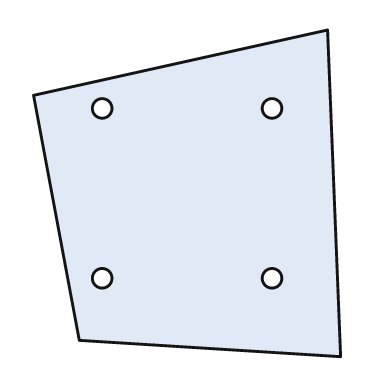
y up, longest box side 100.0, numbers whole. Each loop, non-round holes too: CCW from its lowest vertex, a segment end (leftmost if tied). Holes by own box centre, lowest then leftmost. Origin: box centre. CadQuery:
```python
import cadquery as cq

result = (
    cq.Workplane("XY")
    .moveTo(47.0, -50.0)
    .lineTo(43.0, 50.0)
    .lineTo(-47.0, 30.0)
    .lineTo(-33.0, -45.0)
    .close()
    .moveTo(-26.0, -26.0)
    .circle(3.0)
    .moveTo(26.0, -26.0)
    .circle(3.0)
    .moveTo(-26.0, 26.0)
    .circle(3.0)
    .moveTo(26.0, 26.0)
    .circle(3.0)
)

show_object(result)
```